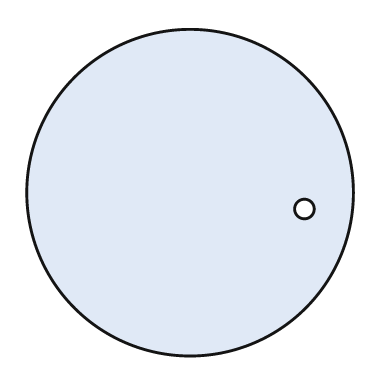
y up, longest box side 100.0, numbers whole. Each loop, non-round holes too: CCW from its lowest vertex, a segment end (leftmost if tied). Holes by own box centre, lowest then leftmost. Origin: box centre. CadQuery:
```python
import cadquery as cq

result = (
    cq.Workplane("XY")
    .moveTo(0.0, 0.0)
    .circle(50.0)
    .moveTo(35.0, -5.0)
    .circle(3.0)
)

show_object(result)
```